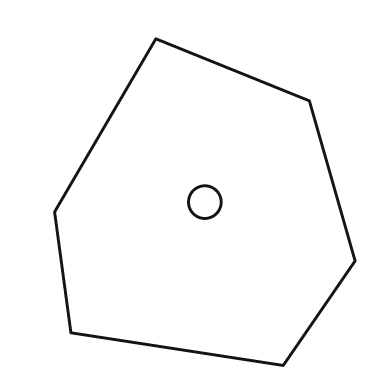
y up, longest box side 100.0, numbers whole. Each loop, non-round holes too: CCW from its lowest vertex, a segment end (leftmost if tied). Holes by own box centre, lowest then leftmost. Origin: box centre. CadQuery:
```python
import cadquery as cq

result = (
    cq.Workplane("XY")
    .moveTo(24.0, -50.0)
    .lineTo(46.0, -18.0)
    .lineTo(32.0, 31.0)
    .lineTo(-15.0, 50.0)
    .lineTo(-46.0, -3.0)
    .lineTo(-41.0, -40.0)
    .close()
    .moveTo(0.0, 0.0)
    .circle(5.0)
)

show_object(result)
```